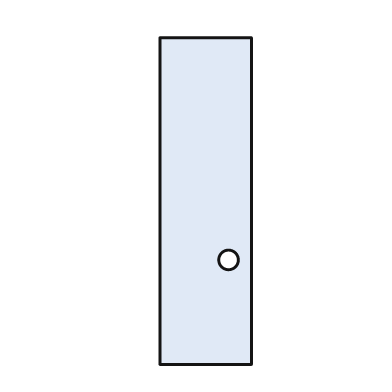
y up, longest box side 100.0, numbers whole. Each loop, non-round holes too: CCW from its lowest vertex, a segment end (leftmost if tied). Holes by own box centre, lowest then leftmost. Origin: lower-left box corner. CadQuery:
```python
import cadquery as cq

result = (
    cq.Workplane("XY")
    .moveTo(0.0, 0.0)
    .lineTo(28.0, 0.0)
    .lineTo(28.0, 100.0)
    .lineTo(0.0, 100.0)
    .close()
    .moveTo(21.0, 32.0)
    .circle(3.0)
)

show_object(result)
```